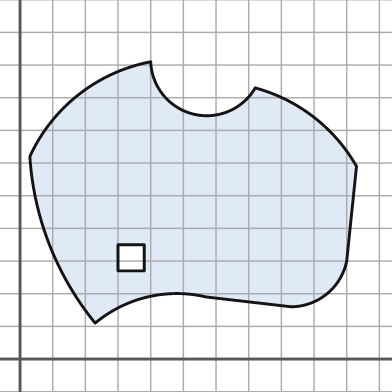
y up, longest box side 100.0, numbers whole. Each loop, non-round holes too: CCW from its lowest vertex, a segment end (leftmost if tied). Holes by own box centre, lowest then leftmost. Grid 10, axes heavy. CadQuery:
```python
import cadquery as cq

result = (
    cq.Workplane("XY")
    .moveTo(23.0, 11.0)
    .threePointArc((39.0, 19.0), (57.0, 19.0))
    .lineTo(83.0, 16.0)
    .threePointArc((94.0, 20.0), (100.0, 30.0))
    .lineTo(103.0, 59.0)
    .threePointArc((90.0, 74.0), (72.0, 83.0))
    .threePointArc((53.0, 75.0), (40.0, 91.0))
    .threePointArc((18.0, 81.0), (3.0, 62.0))
    .threePointArc((9.0, 35.0), (23.0, 11.0))
    .close()
    .moveTo(30.0, 27.0)
    .lineTo(38.0, 27.0)
    .lineTo(38.0, 35.0)
    .lineTo(30.0, 35.0)
    .close()
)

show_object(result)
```